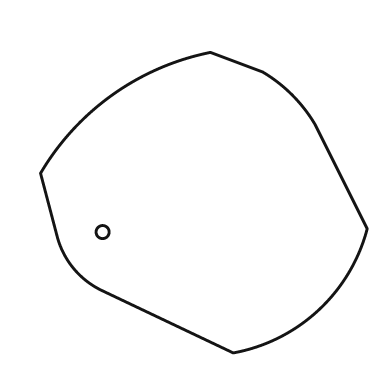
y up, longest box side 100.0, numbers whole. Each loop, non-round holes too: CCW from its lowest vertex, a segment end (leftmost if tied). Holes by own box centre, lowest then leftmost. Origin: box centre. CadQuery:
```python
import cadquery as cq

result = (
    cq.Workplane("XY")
    .moveTo(9.0, -46.0)
    .threePointArc((35.0, -33.0), (50.0, -8.0))
    .lineTo(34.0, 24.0)
    .threePointArc((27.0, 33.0), (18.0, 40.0))
    .lineTo(2.0, 46.0)
    .threePointArc((-28.0, 33.0), (-50.0, 9.0))
    .lineTo(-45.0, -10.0)
    .threePointArc((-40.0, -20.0), (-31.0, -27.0))
    .close()
    .moveTo(-31.0, -9.0)
    .circle(2.0)
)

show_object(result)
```